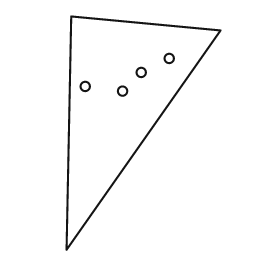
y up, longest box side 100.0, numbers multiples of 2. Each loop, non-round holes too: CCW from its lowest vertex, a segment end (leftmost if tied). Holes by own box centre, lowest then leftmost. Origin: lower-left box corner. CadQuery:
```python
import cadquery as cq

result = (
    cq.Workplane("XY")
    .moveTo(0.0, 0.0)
    .lineTo(66.0, 94.0)
    .lineTo(2.0, 100.0)
    .close()
    .moveTo(24.0, 68.0)
    .circle(2.0)
    .moveTo(8.0, 70.0)
    .circle(2.0)
    .moveTo(32.0, 76.0)
    .circle(2.0)
    .moveTo(44.0, 82.0)
    .circle(2.0)
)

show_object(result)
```